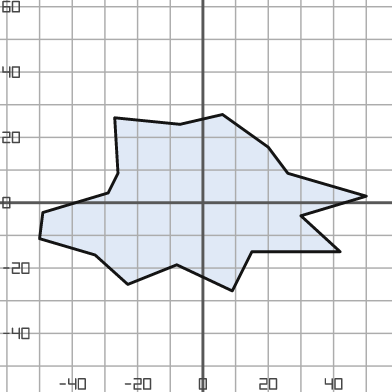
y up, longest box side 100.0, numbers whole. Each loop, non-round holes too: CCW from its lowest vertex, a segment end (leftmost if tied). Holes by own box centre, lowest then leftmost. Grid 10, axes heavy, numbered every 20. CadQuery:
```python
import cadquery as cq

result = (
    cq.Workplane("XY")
    .moveTo(9.0, -27.0)
    .lineTo(15.0, -15.0)
    .lineTo(42.0, -15.0)
    .lineTo(30.0, -4.0)
    .lineTo(50.0, 2.0)
    .lineTo(26.0, 9.0)
    .lineTo(20.0, 17.0)
    .lineTo(6.0, 27.0)
    .lineTo(-7.0, 24.0)
    .lineTo(-27.0, 26.0)
    .lineTo(-26.0, 9.0)
    .lineTo(-29.0, 3.0)
    .lineTo(-49.0, -3.0)
    .lineTo(-50.0, -11.0)
    .lineTo(-33.0, -16.0)
    .lineTo(-23.0, -25.0)
    .lineTo(-8.0, -19.0)
    .close()
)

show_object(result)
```